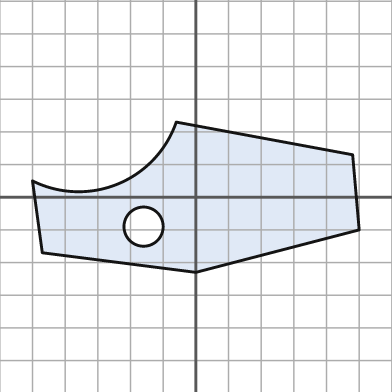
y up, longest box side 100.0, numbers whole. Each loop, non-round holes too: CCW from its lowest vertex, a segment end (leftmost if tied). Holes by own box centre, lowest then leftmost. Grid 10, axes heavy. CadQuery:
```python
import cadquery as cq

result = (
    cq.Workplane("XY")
    .moveTo(0.0, -23.0)
    .lineTo(50.0, -10.0)
    .lineTo(48.0, 13.0)
    .lineTo(-6.0, 23.0)
    .threePointArc((-24.0, 4.0), (-50.0, 5.0))
    .lineTo(-47.0, -17.0)
    .close()
    .moveTo(-16.0, -9.0)
    .circle(6.0)
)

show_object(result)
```